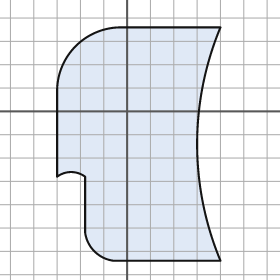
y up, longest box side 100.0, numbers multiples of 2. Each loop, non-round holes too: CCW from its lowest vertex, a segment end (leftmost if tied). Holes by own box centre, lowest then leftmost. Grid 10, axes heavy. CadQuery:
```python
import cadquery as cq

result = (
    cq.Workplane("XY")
    .moveTo(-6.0, -64.0)
    .lineTo(40.0, -64.0)
    .threePointArc((30.0, -14.0), (40.0, 36.0))
    .lineTo(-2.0, 36.0)
    .threePointArc((-22.0, 28.0), (-30.0, 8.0))
    .lineTo(-30.0, -28.0)
    .threePointArc((-24.0, -26.0), (-18.0, -28.0))
    .lineTo(-18.0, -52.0)
    .threePointArc((-14.0, -60.0), (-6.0, -64.0))
    .close()
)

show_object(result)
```